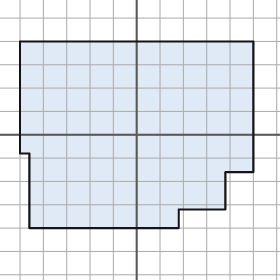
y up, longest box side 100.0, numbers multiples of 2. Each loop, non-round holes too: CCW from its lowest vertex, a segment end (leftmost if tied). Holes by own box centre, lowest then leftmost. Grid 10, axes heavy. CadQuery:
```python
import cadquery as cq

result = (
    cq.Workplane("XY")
    .moveTo(-46.0, -40.0)
    .lineTo(18.0, -40.0)
    .lineTo(18.0, -32.0)
    .lineTo(38.0, -32.0)
    .lineTo(38.0, -16.0)
    .lineTo(50.0, -16.0)
    .lineTo(50.0, 40.0)
    .lineTo(-50.0, 40.0)
    .lineTo(-50.0, -8.0)
    .lineTo(-46.0, -8.0)
    .close()
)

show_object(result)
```